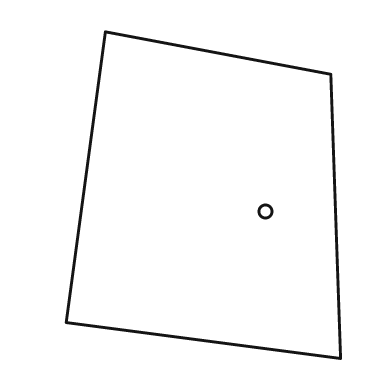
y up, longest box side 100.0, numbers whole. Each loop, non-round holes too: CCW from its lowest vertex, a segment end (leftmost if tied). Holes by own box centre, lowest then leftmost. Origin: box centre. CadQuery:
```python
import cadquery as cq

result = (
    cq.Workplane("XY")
    .moveTo(42.0, -50.0)
    .lineTo(39.0, 37.0)
    .lineTo(-30.0, 50.0)
    .lineTo(-42.0, -39.0)
    .close()
    .moveTo(19.0, -5.0)
    .circle(2.0)
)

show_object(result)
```